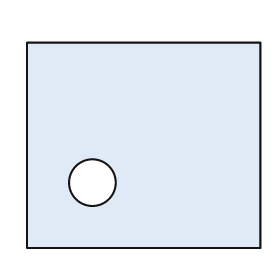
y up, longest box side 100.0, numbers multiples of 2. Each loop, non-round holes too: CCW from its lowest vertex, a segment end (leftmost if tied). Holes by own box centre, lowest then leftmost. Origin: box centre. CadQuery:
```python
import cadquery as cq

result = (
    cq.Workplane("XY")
    .moveTo(-50.0, -44.0)
    .lineTo(50.0, -44.0)
    .lineTo(50.0, 44.0)
    .lineTo(-50.0, 44.0)
    .close()
    .moveTo(-22.0, -16.0)
    .circle(10.0)
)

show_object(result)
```